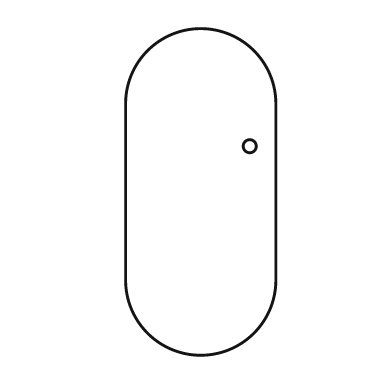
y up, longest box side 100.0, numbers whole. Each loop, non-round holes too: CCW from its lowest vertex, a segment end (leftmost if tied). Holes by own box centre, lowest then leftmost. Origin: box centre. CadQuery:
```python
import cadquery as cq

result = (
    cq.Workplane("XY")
    .moveTo(-23.0, -27.0)
    .threePointArc((0.0, -50.0), (23.0, -27.0))
    .lineTo(23.0, 27.0)
    .threePointArc((0.0, 50.0), (-23.0, 27.0))
    .close()
    .moveTo(15.0, 14.0)
    .circle(2.0)
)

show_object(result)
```